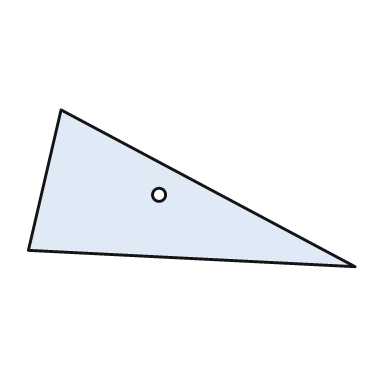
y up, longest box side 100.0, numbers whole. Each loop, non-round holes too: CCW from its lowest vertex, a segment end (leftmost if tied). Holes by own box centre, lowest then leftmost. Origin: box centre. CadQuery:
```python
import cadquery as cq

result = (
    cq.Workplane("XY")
    .moveTo(50.0, -24.0)
    .lineTo(-40.0, 24.0)
    .lineTo(-50.0, -19.0)
    .close()
    .moveTo(-10.0, -2.0)
    .circle(2.0)
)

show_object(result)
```